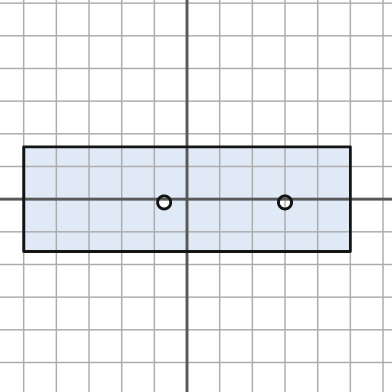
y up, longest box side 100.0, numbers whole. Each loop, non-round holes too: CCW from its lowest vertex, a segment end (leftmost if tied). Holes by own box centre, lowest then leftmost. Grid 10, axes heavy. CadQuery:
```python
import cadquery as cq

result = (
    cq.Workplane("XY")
    .moveTo(-50.0, -16.0)
    .lineTo(50.0, -16.0)
    .lineTo(50.0, 16.0)
    .lineTo(-50.0, 16.0)
    .close()
    .moveTo(-7.0, -1.0)
    .circle(2.0)
    .moveTo(30.0, -1.0)
    .circle(2.0)
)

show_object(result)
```